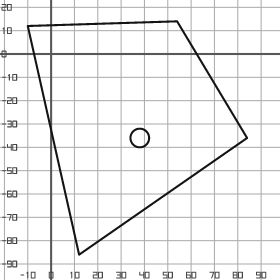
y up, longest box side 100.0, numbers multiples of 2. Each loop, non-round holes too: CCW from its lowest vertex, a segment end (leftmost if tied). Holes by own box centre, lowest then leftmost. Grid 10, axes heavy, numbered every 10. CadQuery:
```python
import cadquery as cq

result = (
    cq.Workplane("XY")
    .moveTo(12.0, -86.0)
    .lineTo(84.0, -36.0)
    .lineTo(54.0, 14.0)
    .lineTo(-10.0, 12.0)
    .close()
    .moveTo(38.0, -36.0)
    .circle(4.0)
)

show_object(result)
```